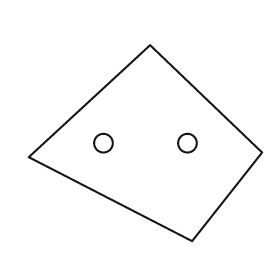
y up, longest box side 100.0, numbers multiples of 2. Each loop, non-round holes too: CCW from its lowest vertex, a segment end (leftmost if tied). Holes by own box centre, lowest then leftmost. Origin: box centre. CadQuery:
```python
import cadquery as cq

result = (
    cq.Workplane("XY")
    .moveTo(20.0, -42.0)
    .lineTo(50.0, -4.0)
    .lineTo(2.0, 42.0)
    .lineTo(-50.0, -6.0)
    .close()
    .moveTo(-18.0, 0.0)
    .circle(4.0)
    .moveTo(18.0, 0.0)
    .circle(4.0)
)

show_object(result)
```